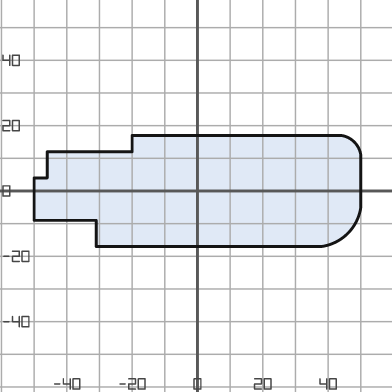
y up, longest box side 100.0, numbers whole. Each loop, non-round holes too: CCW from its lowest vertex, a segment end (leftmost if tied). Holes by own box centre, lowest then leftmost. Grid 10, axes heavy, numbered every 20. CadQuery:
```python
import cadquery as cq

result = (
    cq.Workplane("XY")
    .moveTo(-31.0, -17.0)
    .lineTo(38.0, -17.0)
    .threePointArc((46.0, -13.0), (50.0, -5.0))
    .lineTo(50.0, 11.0)
    .threePointArc((48.0, 15.0), (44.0, 17.0))
    .lineTo(-20.0, 17.0)
    .lineTo(-20.0, 12.0)
    .lineTo(-46.0, 12.0)
    .lineTo(-46.0, 4.0)
    .lineTo(-50.0, 4.0)
    .lineTo(-50.0, -9.0)
    .lineTo(-31.0, -9.0)
    .close()
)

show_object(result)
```